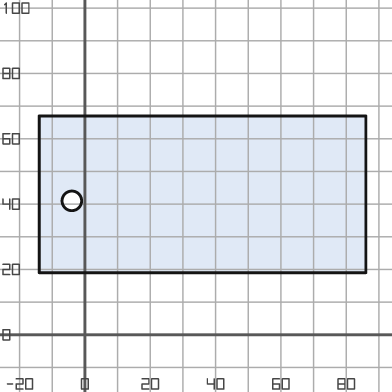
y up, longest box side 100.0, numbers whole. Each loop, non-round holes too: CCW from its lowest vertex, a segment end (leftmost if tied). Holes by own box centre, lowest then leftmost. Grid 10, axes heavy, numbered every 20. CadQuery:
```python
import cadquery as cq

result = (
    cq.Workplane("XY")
    .moveTo(-14.0, 19.0)
    .lineTo(86.0, 19.0)
    .lineTo(86.0, 67.0)
    .lineTo(-14.0, 67.0)
    .close()
    .moveTo(-4.0, 41.0)
    .circle(3.0)
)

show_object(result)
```